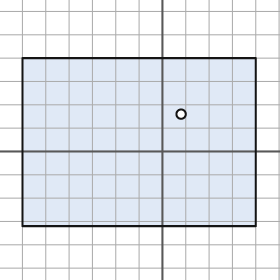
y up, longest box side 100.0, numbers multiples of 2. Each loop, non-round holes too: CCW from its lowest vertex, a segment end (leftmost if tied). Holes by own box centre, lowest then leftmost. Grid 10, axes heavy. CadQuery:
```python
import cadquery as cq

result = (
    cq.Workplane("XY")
    .moveTo(-60.0, -32.0)
    .lineTo(40.0, -32.0)
    .lineTo(40.0, 40.0)
    .lineTo(-60.0, 40.0)
    .close()
    .moveTo(8.0, 16.0)
    .circle(2.0)
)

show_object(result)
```